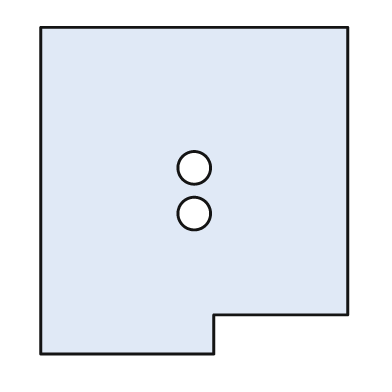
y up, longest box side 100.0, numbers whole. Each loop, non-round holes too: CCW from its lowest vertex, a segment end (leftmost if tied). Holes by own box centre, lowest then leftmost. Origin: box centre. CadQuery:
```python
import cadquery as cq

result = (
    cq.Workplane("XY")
    .moveTo(-47.0, -50.0)
    .lineTo(6.0, -50.0)
    .lineTo(6.0, -38.0)
    .lineTo(47.0, -38.0)
    .lineTo(47.0, 50.0)
    .lineTo(-47.0, 50.0)
    .close()
    .moveTo(0.0, -7.0)
    .circle(5.0)
    .moveTo(0.0, 7.0)
    .circle(5.0)
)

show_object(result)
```